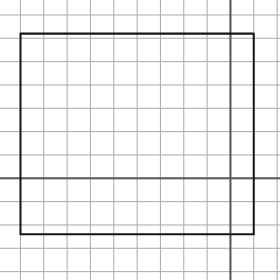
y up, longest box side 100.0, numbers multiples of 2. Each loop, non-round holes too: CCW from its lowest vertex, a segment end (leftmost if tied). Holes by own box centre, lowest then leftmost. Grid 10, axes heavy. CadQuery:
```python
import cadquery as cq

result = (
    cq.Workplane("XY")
    .moveTo(-90.0, -24.0)
    .lineTo(10.0, -24.0)
    .lineTo(10.0, 62.0)
    .lineTo(-90.0, 62.0)
    .close()
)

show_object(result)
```